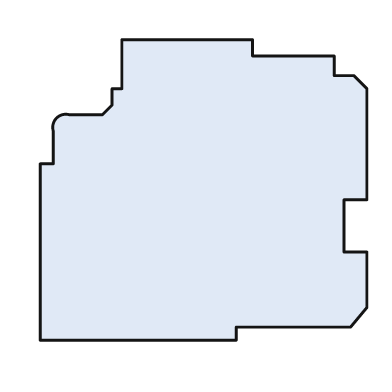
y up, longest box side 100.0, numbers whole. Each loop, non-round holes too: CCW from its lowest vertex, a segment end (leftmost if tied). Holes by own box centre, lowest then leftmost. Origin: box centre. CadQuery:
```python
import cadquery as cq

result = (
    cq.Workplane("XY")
    .moveTo(-50.0, -46.0)
    .lineTo(10.0, -46.0)
    .lineTo(10.0, -42.0)
    .lineTo(45.0, -42.0)
    .lineTo(50.0, -36.0)
    .lineTo(50.0, -19.0)
    .lineTo(43.0, -19.0)
    .lineTo(43.0, -3.0)
    .lineTo(50.0, -3.0)
    .lineTo(50.0, 31.0)
    .lineTo(46.0, 35.0)
    .lineTo(40.0, 35.0)
    .lineTo(40.0, 41.0)
    .lineTo(15.0, 41.0)
    .lineTo(15.0, 46.0)
    .lineTo(-25.0, 46.0)
    .lineTo(-25.0, 31.0)
    .lineTo(-28.0, 31.0)
    .lineTo(-28.0, 26.0)
    .lineTo(-31.0, 23.0)
    .lineTo(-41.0, 23.0)
    .threePointArc((-45.0, 22.0), (-46.0, 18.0))
    .lineTo(-46.0, 8.0)
    .lineTo(-50.0, 8.0)
    .close()
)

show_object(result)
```